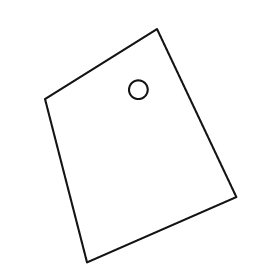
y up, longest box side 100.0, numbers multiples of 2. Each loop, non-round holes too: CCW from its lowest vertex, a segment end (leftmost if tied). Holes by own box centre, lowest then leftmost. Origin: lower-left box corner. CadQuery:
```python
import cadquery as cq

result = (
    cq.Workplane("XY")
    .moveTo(18.0, 0.0)
    .lineTo(82.0, 28.0)
    .lineTo(48.0, 100.0)
    .lineTo(0.0, 70.0)
    .close()
    .moveTo(40.0, 74.0)
    .circle(4.0)
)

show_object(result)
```